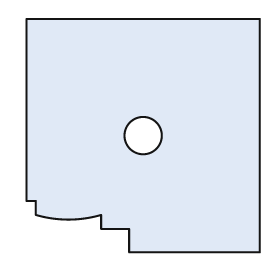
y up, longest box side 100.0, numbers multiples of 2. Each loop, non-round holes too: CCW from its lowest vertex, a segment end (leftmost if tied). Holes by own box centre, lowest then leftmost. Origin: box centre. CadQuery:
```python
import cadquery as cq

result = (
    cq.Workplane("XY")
    .moveTo(-6.0, -50.0)
    .lineTo(50.0, -50.0)
    .lineTo(50.0, 50.0)
    .lineTo(-50.0, 50.0)
    .lineTo(-50.0, -28.0)
    .lineTo(-46.0, -28.0)
    .lineTo(-46.0, -34.0)
    .threePointArc((-32.0, -36.0), (-18.0, -34.0))
    .lineTo(-18.0, -40.0)
    .lineTo(-6.0, -40.0)
    .close()
    .moveTo(0.0, 0.0)
    .circle(8.0)
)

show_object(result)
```